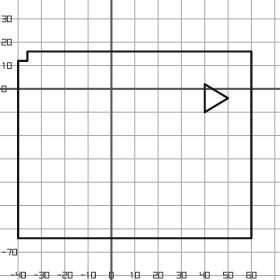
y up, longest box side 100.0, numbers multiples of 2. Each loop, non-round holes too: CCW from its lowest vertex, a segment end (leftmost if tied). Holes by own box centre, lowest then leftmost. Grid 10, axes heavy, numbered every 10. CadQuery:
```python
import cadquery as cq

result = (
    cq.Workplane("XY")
    .moveTo(-40.0, -64.0)
    .lineTo(60.0, -64.0)
    .lineTo(60.0, 16.0)
    .lineTo(-36.0, 16.0)
    .lineTo(-36.0, 12.0)
    .lineTo(-40.0, 12.0)
    .close()
    .moveTo(40.0, -10.0)
    .lineTo(50.0, -4.0)
    .lineTo(40.0, 2.0)
    .close()
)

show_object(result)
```